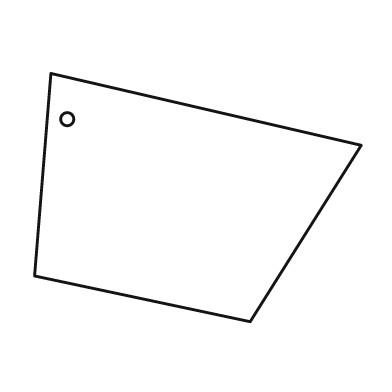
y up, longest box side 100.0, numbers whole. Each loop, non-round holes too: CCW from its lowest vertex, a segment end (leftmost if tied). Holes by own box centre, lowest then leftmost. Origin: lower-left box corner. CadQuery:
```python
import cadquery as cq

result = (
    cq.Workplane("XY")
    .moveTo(66.0, 0.0)
    .lineTo(100.0, 54.0)
    .lineTo(5.0, 76.0)
    .lineTo(0.0, 14.0)
    .close()
    .moveTo(10.0, 62.0)
    .circle(2.0)
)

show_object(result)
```